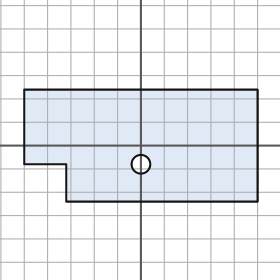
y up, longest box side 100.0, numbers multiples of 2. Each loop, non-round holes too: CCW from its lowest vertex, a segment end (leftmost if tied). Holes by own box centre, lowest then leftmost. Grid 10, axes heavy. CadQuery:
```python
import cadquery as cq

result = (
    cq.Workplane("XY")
    .moveTo(-32.0, -24.0)
    .lineTo(50.0, -24.0)
    .lineTo(50.0, 24.0)
    .lineTo(-50.0, 24.0)
    .lineTo(-50.0, -8.0)
    .lineTo(-32.0, -8.0)
    .close()
    .moveTo(0.0, -8.0)
    .circle(4.0)
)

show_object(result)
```